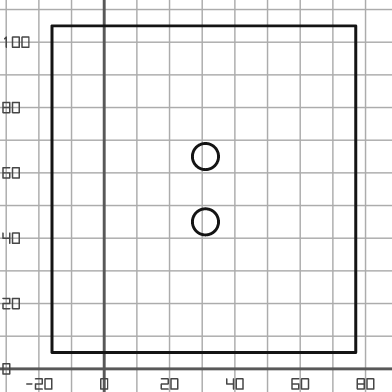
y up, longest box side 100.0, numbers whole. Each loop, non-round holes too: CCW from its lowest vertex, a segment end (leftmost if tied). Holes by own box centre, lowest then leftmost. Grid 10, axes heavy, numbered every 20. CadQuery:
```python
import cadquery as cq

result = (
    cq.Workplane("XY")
    .moveTo(-16.0, 5.0)
    .lineTo(77.0, 5.0)
    .lineTo(77.0, 105.0)
    .lineTo(-16.0, 105.0)
    .close()
    .moveTo(31.0, 45.0)
    .circle(4.0)
    .moveTo(31.0, 65.0)
    .circle(4.0)
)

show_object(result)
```